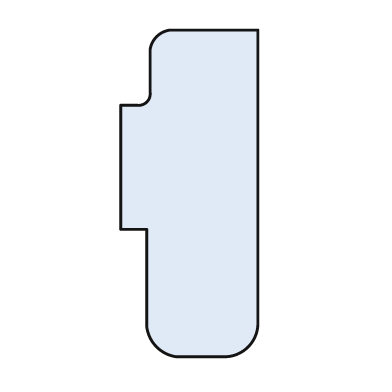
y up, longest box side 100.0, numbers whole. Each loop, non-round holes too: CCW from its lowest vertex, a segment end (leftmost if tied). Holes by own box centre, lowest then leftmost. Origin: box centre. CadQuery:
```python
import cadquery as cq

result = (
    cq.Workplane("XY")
    .moveTo(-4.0, -50.0)
    .lineTo(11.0, -50.0)
    .threePointArc((18.0, -47.0), (21.0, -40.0))
    .lineTo(21.0, 50.0)
    .lineTo(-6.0, 50.0)
    .threePointArc((-10.0, 48.0), (-12.0, 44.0))
    .lineTo(-12.0, 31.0)
    .threePointArc((-13.0, 28.0), (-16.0, 27.0))
    .lineTo(-21.0, 27.0)
    .lineTo(-21.0, -11.0)
    .lineTo(-13.0, -11.0)
    .lineTo(-13.0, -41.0)
    .threePointArc((-10.0, -47.0), (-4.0, -50.0))
    .close()
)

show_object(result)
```